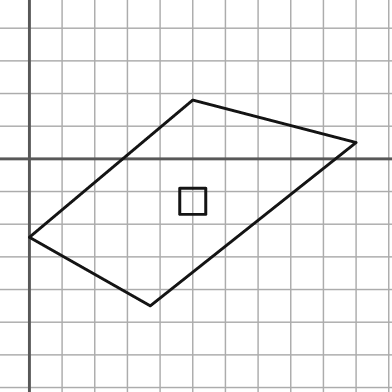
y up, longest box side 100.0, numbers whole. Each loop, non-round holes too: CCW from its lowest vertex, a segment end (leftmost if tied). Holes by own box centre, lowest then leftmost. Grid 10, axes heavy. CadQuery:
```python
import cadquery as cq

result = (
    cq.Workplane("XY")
    .moveTo(37.0, -45.0)
    .lineTo(100.0, 5.0)
    .lineTo(50.0, 18.0)
    .lineTo(0.0, -24.0)
    .close()
    .moveTo(46.0, -17.0)
    .lineTo(54.0, -17.0)
    .lineTo(54.0, -9.0)
    .lineTo(46.0, -9.0)
    .close()
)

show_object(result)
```